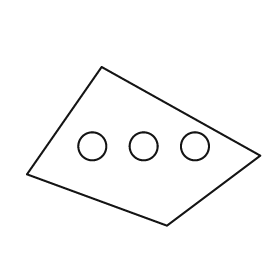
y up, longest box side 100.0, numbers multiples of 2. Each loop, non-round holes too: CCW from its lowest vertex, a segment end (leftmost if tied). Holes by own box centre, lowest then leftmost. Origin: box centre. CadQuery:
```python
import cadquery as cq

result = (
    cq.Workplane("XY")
    .moveTo(10.0, -34.0)
    .lineTo(50.0, -4.0)
    .lineTo(-18.0, 34.0)
    .lineTo(-50.0, -12.0)
    .close()
    .moveTo(-22.0, 0.0)
    .circle(6.0)
    .moveTo(0.0, 0.0)
    .circle(6.0)
    .moveTo(22.0, 0.0)
    .circle(6.0)
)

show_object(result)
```